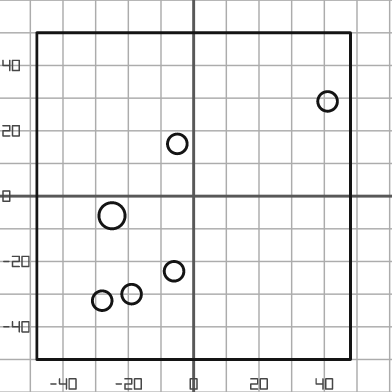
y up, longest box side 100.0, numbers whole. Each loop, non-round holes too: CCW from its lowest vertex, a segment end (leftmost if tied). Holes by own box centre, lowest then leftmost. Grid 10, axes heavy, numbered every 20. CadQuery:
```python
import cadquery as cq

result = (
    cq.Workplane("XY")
    .moveTo(-48.0, -50.0)
    .lineTo(48.0, -50.0)
    .lineTo(48.0, 50.0)
    .lineTo(-48.0, 50.0)
    .close()
    .moveTo(-28.0, -32.0)
    .circle(3.0)
    .moveTo(-19.0, -30.0)
    .circle(3.0)
    .moveTo(-6.0, -23.0)
    .circle(3.0)
    .moveTo(-25.0, -6.0)
    .circle(4.0)
    .moveTo(-5.0, 16.0)
    .circle(3.0)
    .moveTo(41.0, 29.0)
    .circle(3.0)
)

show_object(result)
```